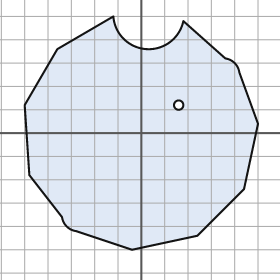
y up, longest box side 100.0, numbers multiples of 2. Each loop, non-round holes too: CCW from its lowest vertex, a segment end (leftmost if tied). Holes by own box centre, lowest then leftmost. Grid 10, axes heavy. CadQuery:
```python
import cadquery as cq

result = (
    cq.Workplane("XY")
    .moveTo(-4.0, -50.0)
    .lineTo(24.0, -44.0)
    .lineTo(44.0, -24.0)
    .lineTo(50.0, 4.0)
    .lineTo(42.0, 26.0)
    .threePointArc((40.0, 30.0), (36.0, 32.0))
    .lineTo(18.0, 48.0)
    .threePointArc((2.0, 36.0), (-12.0, 50.0))
    .lineTo(-36.0, 36.0)
    .lineTo(-50.0, 12.0)
    .lineTo(-48.0, -18.0)
    .lineTo(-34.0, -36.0)
    .threePointArc((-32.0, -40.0), (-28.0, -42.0))
    .close()
    .moveTo(16.0, 12.0)
    .circle(2.0)
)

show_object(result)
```